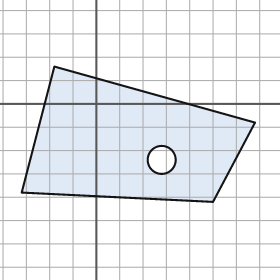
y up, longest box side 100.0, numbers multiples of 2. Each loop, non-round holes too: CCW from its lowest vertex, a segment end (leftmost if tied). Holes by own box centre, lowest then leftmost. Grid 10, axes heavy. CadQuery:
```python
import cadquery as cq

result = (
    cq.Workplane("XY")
    .moveTo(50.0, -42.0)
    .lineTo(68.0, -8.0)
    .lineTo(-18.0, 16.0)
    .lineTo(-32.0, -38.0)
    .close()
    .moveTo(28.0, -24.0)
    .circle(6.0)
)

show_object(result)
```